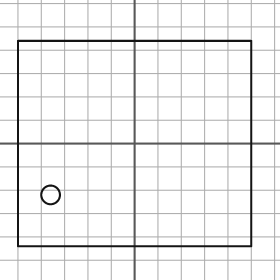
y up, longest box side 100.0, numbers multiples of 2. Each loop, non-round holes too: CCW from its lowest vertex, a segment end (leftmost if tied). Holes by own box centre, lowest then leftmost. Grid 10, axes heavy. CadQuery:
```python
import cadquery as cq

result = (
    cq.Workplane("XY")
    .moveTo(-50.0, -44.0)
    .lineTo(50.0, -44.0)
    .lineTo(50.0, 44.0)
    .lineTo(-50.0, 44.0)
    .close()
    .moveTo(-36.0, -22.0)
    .circle(4.0)
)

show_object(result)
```